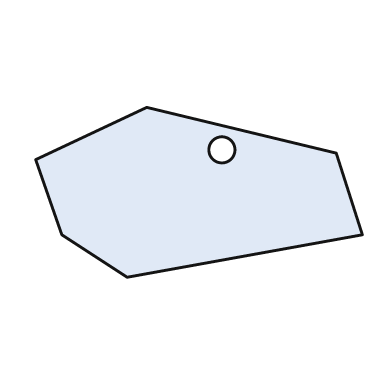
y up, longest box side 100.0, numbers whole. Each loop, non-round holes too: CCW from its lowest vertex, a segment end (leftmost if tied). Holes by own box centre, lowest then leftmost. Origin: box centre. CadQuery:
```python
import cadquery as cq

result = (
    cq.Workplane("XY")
    .moveTo(-22.0, -26.0)
    .lineTo(50.0, -13.0)
    .lineTo(42.0, 12.0)
    .lineTo(-16.0, 26.0)
    .lineTo(-50.0, 10.0)
    .lineTo(-42.0, -13.0)
    .close()
    .moveTo(7.0, 13.0)
    .circle(4.0)
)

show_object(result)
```